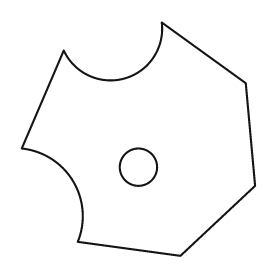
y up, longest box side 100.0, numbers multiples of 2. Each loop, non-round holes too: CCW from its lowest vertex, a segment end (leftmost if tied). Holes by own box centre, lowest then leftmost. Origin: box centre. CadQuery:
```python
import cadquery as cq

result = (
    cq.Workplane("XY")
    .moveTo(18.0, -50.0)
    .lineTo(50.0, -20.0)
    .lineTo(46.0, 24.0)
    .lineTo(10.0, 50.0)
    .threePointArc((-6.0, 26.0), (-32.0, 38.0))
    .lineTo(-50.0, -4.0)
    .threePointArc((-28.0, -18.0), (-26.0, -44.0))
    .close()
    .moveTo(0.0, -12.0)
    .circle(8.0)
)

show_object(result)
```